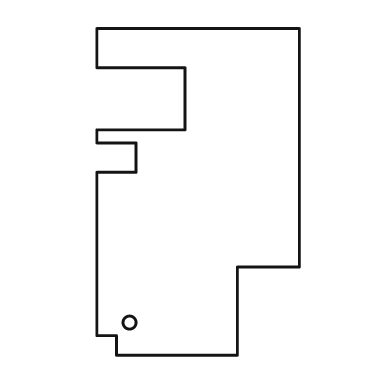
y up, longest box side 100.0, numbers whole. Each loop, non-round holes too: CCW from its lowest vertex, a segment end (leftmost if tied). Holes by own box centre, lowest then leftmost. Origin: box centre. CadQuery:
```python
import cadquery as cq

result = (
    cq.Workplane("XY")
    .moveTo(-25.0, -50.0)
    .lineTo(12.0, -50.0)
    .lineTo(12.0, -23.0)
    .lineTo(31.0, -23.0)
    .lineTo(31.0, 50.0)
    .lineTo(-31.0, 50.0)
    .lineTo(-31.0, 38.0)
    .lineTo(-4.0, 38.0)
    .lineTo(-4.0, 19.0)
    .lineTo(-31.0, 19.0)
    .lineTo(-31.0, 15.0)
    .lineTo(-19.0, 15.0)
    .lineTo(-19.0, 6.0)
    .lineTo(-31.0, 6.0)
    .lineTo(-31.0, -44.0)
    .lineTo(-25.0, -44.0)
    .close()
    .moveTo(-21.0, -40.0)
    .circle(2.0)
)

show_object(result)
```